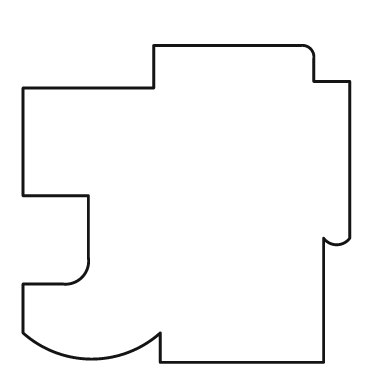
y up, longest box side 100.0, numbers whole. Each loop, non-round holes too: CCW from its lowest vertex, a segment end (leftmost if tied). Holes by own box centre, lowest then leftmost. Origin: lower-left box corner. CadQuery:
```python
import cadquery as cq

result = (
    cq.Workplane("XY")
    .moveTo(42.0, 0.0)
    .lineTo(92.0, 0.0)
    .lineTo(92.0, 38.0)
    .threePointArc((96.0, 36.0), (100.0, 38.0))
    .lineTo(100.0, 86.0)
    .lineTo(89.0, 86.0)
    .lineTo(89.0, 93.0)
    .threePointArc((88.0, 96.0), (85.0, 97.0))
    .lineTo(40.0, 97.0)
    .lineTo(40.0, 84.0)
    .lineTo(0.0, 84.0)
    .lineTo(0.0, 51.0)
    .lineTo(20.0, 51.0)
    .lineTo(20.0, 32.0)
    .threePointArc((18.0, 26.0), (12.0, 24.0))
    .lineTo(0.0, 24.0)
    .lineTo(0.0, 9.0)
    .threePointArc((21.0, 1.0), (42.0, 9.0))
    .close()
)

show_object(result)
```